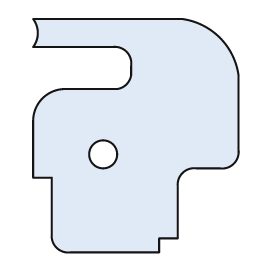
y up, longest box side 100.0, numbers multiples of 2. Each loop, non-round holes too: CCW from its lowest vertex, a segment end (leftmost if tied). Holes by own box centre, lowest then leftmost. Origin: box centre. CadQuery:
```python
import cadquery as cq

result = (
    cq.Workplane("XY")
    .moveTo(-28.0, -50.0)
    .lineTo(10.0, -50.0)
    .lineTo(10.0, -44.0)
    .lineTo(18.0, -44.0)
    .lineTo(18.0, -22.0)
    .threePointArc((20.0, -16.0), (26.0, -14.0))
    .lineTo(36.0, -14.0)
    .threePointArc((42.0, -12.0), (44.0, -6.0))
    .lineTo(44.0, 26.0)
    .threePointArc((36.0, 42.0), (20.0, 50.0))
    .lineTo(-44.0, 50.0)
    .threePointArc((-42.0, 44.0), (-44.0, 38.0))
    .lineTo(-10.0, 38.0)
    .threePointArc((-4.0, 36.0), (-2.0, 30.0))
    .lineTo(-2.0, 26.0)
    .threePointArc((-4.0, 22.0), (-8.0, 20.0))
    .lineTo(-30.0, 20.0)
    .threePointArc((-40.0, 16.0), (-44.0, 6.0))
    .lineTo(-44.0, -18.0)
    .lineTo(-36.0, -18.0)
    .lineTo(-36.0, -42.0)
    .threePointArc((-34.0, -48.0), (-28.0, -50.0))
    .close()
    .moveTo(-14.0, -8.0)
    .circle(6.0)
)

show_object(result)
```